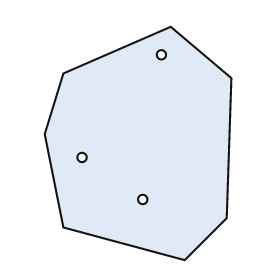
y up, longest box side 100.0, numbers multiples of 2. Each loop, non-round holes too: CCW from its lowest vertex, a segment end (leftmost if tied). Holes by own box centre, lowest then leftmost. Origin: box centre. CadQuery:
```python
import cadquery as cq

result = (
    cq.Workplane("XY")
    .moveTo(20.0, -50.0)
    .lineTo(38.0, -32.0)
    .lineTo(40.0, 28.0)
    .lineTo(14.0, 50.0)
    .lineTo(-32.0, 30.0)
    .lineTo(-40.0, 4.0)
    .lineTo(-32.0, -36.0)
    .close()
    .moveTo(2.0, -24.0)
    .circle(2.0)
    .moveTo(-24.0, -6.0)
    .circle(2.0)
    .moveTo(10.0, 38.0)
    .circle(2.0)
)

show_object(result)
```